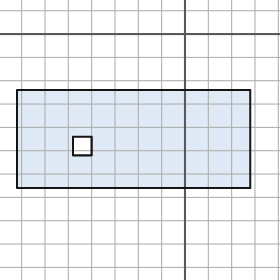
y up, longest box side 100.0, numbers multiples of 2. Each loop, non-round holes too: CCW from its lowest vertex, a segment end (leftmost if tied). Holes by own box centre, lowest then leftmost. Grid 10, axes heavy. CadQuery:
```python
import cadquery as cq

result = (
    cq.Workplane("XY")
    .moveTo(-72.0, -66.0)
    .lineTo(28.0, -66.0)
    .lineTo(28.0, -24.0)
    .lineTo(-72.0, -24.0)
    .close()
    .moveTo(-48.0, -52.0)
    .lineTo(-40.0, -52.0)
    .lineTo(-40.0, -44.0)
    .lineTo(-48.0, -44.0)
    .close()
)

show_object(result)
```